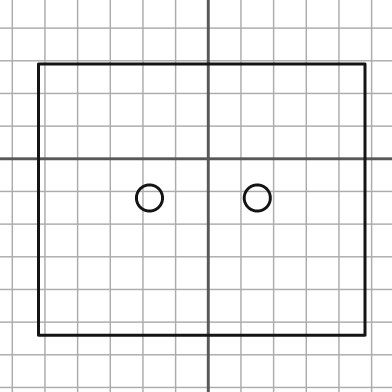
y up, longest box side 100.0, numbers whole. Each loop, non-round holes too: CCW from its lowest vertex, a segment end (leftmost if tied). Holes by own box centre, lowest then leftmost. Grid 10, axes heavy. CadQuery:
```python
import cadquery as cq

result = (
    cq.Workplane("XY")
    .moveTo(-52.0, -54.0)
    .lineTo(48.0, -54.0)
    .lineTo(48.0, 29.0)
    .lineTo(-52.0, 29.0)
    .close()
    .moveTo(-18.0, -12.0)
    .circle(4.0)
    .moveTo(15.0, -12.0)
    .circle(4.0)
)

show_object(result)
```